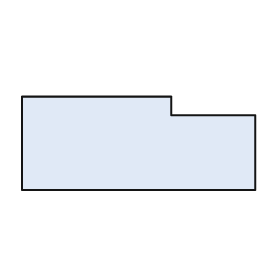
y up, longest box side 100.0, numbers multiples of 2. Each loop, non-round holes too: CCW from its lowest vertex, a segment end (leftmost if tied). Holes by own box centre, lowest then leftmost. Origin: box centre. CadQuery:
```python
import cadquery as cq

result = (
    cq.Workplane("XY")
    .moveTo(-50.0, -20.0)
    .lineTo(50.0, -20.0)
    .lineTo(50.0, 12.0)
    .lineTo(14.0, 12.0)
    .lineTo(14.0, 20.0)
    .lineTo(-50.0, 20.0)
    .close()
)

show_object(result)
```